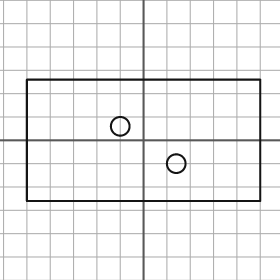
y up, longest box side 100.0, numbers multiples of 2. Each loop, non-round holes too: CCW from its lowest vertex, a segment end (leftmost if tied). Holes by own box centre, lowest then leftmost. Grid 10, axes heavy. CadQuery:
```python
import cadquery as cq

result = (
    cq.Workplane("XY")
    .moveTo(-50.0, -26.0)
    .lineTo(50.0, -26.0)
    .lineTo(50.0, 26.0)
    .lineTo(-50.0, 26.0)
    .close()
    .moveTo(14.0, -10.0)
    .circle(4.0)
    .moveTo(-10.0, 6.0)
    .circle(4.0)
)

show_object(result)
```